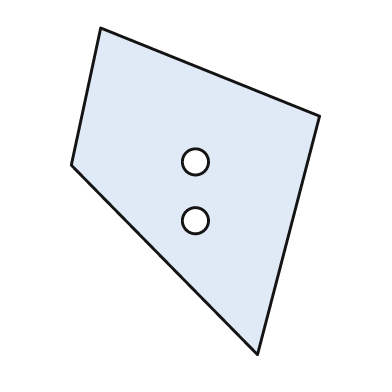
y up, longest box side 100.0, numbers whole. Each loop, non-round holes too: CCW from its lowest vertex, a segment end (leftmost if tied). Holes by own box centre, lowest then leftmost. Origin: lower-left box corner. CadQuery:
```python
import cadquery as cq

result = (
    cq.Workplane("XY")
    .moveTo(57.0, 0.0)
    .lineTo(76.0, 73.0)
    .lineTo(9.0, 100.0)
    .lineTo(0.0, 58.0)
    .close()
    .moveTo(38.0, 41.0)
    .circle(4.0)
    .moveTo(38.0, 59.0)
    .circle(4.0)
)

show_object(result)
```